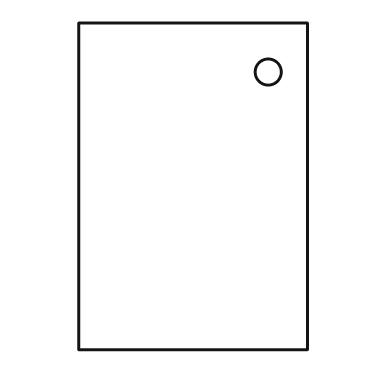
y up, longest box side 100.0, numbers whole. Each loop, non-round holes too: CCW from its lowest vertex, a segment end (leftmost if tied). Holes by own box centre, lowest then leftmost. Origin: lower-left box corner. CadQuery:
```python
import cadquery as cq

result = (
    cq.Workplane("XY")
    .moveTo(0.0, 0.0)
    .lineTo(70.0, 0.0)
    .lineTo(70.0, 100.0)
    .lineTo(0.0, 100.0)
    .close()
    .moveTo(58.0, 85.0)
    .circle(4.0)
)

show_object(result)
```